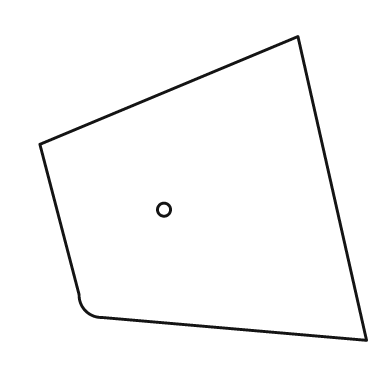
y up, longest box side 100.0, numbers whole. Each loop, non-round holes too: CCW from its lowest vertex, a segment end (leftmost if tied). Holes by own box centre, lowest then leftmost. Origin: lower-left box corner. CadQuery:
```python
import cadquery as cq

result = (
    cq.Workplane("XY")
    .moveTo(100.0, 0.0)
    .lineTo(79.0, 93.0)
    .lineTo(0.0, 60.0)
    .lineTo(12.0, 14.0)
    .threePointArc((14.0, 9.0), (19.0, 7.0))
    .close()
    .moveTo(38.0, 40.0)
    .circle(2.0)
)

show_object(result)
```